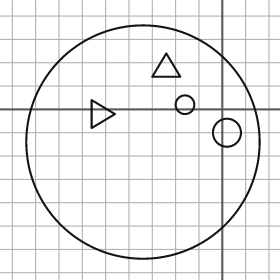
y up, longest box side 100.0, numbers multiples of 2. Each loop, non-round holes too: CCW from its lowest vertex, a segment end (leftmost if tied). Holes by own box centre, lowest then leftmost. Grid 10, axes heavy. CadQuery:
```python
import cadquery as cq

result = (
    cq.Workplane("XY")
    .moveTo(-34.0, -14.0)
    .circle(50.0)
    .moveTo(2.0, -10.0)
    .circle(6.0)
    .moveTo(-56.0, -8.0)
    .lineTo(-46.0, -2.0)
    .lineTo(-56.0, 4.0)
    .close()
    .moveTo(-16.0, 2.0)
    .circle(4.0)
    .moveTo(-30.0, 14.0)
    .lineTo(-18.0, 14.0)
    .lineTo(-24.0, 24.0)
    .close()
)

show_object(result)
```